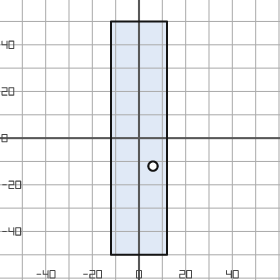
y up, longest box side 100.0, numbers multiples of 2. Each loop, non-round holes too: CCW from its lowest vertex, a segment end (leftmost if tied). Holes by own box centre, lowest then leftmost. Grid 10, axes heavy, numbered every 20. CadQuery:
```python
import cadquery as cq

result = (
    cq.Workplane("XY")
    .moveTo(-12.0, -50.0)
    .lineTo(12.0, -50.0)
    .lineTo(12.0, 50.0)
    .lineTo(-12.0, 50.0)
    .close()
    .moveTo(6.0, -12.0)
    .circle(2.0)
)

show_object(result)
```